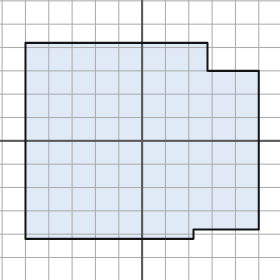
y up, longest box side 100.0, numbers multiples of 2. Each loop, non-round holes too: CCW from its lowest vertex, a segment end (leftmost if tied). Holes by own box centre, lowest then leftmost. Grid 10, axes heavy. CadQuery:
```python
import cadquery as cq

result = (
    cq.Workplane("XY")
    .moveTo(-50.0, -42.0)
    .lineTo(22.0, -42.0)
    .lineTo(22.0, -38.0)
    .lineTo(50.0, -38.0)
    .lineTo(50.0, 30.0)
    .lineTo(28.0, 30.0)
    .lineTo(28.0, 42.0)
    .lineTo(-50.0, 42.0)
    .close()
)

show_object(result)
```